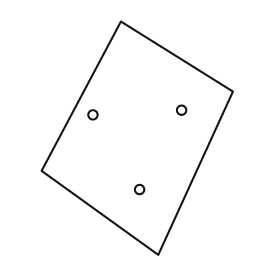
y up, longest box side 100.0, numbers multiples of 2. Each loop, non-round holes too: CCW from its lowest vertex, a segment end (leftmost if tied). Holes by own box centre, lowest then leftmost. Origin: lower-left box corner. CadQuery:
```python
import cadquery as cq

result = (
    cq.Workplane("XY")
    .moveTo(50.0, 0.0)
    .lineTo(82.0, 70.0)
    .lineTo(34.0, 100.0)
    .lineTo(0.0, 36.0)
    .close()
    .moveTo(42.0, 28.0)
    .circle(2.0)
    .moveTo(22.0, 60.0)
    .circle(2.0)
    .moveTo(60.0, 62.0)
    .circle(2.0)
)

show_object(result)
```